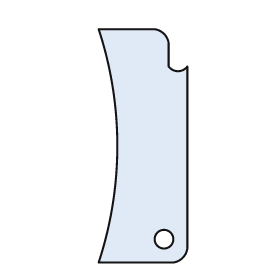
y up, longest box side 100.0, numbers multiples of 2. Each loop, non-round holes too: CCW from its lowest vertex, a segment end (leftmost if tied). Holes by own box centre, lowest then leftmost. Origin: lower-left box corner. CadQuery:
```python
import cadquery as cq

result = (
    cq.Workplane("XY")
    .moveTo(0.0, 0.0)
    .lineTo(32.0, 0.0)
    .threePointArc((36.0, 2.0), (38.0, 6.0))
    .lineTo(38.0, 84.0)
    .threePointArc((34.0, 82.0), (30.0, 84.0))
    .lineTo(30.0, 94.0)
    .threePointArc((28.0, 98.0), (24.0, 100.0))
    .lineTo(0.0, 100.0)
    .threePointArc((8.0, 50.0), (0.0, 0.0))
    .close()
    .moveTo(28.0, 10.0)
    .circle(4.0)
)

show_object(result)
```